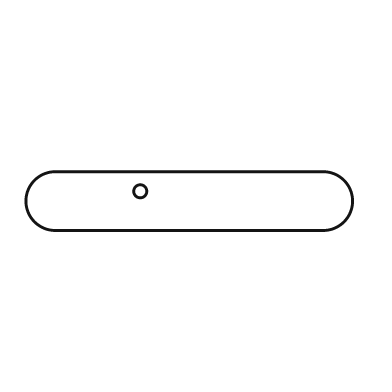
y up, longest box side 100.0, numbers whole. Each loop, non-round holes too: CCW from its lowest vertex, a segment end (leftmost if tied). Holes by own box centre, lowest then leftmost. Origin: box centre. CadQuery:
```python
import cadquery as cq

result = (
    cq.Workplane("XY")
    .moveTo(-41.0, -9.0)
    .lineTo(41.0, -9.0)
    .threePointArc((50.0, 0.0), (41.0, 9.0))
    .lineTo(-41.0, 9.0)
    .threePointArc((-50.0, 0.0), (-41.0, -9.0))
    .close()
    .moveTo(-15.0, 3.0)
    .circle(2.0)
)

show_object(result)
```